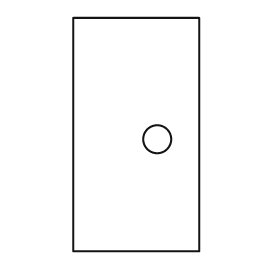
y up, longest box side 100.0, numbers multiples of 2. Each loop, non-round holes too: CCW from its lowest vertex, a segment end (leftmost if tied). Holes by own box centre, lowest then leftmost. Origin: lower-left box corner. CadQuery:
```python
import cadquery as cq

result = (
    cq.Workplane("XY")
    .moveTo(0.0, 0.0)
    .lineTo(54.0, 0.0)
    .lineTo(54.0, 100.0)
    .lineTo(0.0, 100.0)
    .close()
    .moveTo(36.0, 48.0)
    .circle(6.0)
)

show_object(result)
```